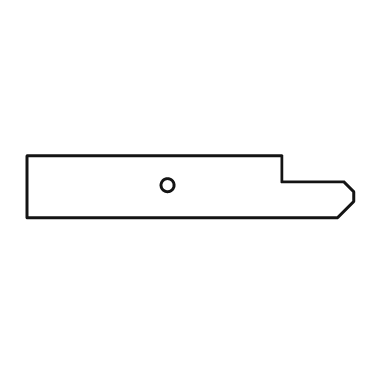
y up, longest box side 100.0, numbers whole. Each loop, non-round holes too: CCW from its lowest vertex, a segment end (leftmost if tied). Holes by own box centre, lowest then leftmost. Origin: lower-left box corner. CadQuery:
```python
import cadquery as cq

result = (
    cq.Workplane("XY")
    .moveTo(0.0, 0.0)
    .lineTo(95.0, 0.0)
    .lineTo(100.0, 5.0)
    .lineTo(100.0, 8.0)
    .lineTo(97.0, 11.0)
    .lineTo(78.0, 11.0)
    .lineTo(78.0, 19.0)
    .lineTo(0.0, 19.0)
    .close()
    .moveTo(43.0, 10.0)
    .circle(2.0)
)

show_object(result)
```